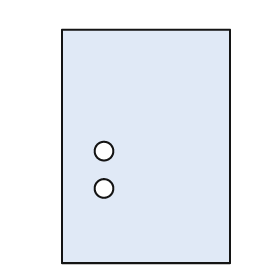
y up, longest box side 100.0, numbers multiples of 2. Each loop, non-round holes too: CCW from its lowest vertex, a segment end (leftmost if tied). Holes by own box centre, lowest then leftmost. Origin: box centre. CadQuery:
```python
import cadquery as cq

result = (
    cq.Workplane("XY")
    .moveTo(-36.0, -50.0)
    .lineTo(36.0, -50.0)
    .lineTo(36.0, 50.0)
    .lineTo(-36.0, 50.0)
    .close()
    .moveTo(-18.0, -18.0)
    .circle(4.0)
    .moveTo(-18.0, -2.0)
    .circle(4.0)
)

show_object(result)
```